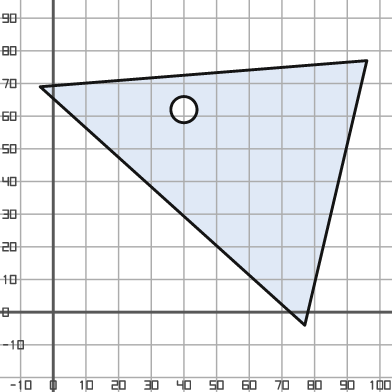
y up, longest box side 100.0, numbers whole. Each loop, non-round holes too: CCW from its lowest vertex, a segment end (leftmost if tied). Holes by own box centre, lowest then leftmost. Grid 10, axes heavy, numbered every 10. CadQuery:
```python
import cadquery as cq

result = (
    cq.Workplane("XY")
    .moveTo(77.0, -4.0)
    .lineTo(96.0, 77.0)
    .lineTo(-4.0, 69.0)
    .close()
    .moveTo(40.0, 62.0)
    .circle(4.0)
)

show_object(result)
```